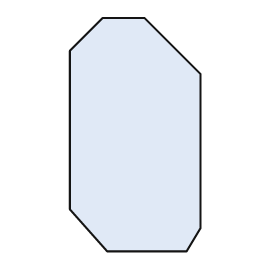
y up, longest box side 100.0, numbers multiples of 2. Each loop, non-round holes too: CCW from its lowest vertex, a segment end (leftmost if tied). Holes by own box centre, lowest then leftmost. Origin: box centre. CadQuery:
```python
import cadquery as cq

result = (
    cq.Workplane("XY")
    .moveTo(-12.0, -50.0)
    .lineTo(22.0, -50.0)
    .lineTo(28.0, -40.0)
    .lineTo(28.0, 26.0)
    .lineTo(4.0, 50.0)
    .lineTo(-14.0, 50.0)
    .lineTo(-28.0, 36.0)
    .lineTo(-28.0, -32.0)
    .close()
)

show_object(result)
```